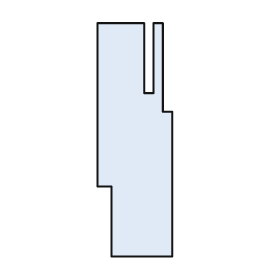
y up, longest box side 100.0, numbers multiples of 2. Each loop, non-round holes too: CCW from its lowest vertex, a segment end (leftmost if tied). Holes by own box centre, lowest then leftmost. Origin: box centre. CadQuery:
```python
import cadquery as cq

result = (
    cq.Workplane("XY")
    .moveTo(-10.0, -50.0)
    .lineTo(16.0, -50.0)
    .lineTo(16.0, 12.0)
    .lineTo(12.0, 12.0)
    .lineTo(12.0, 50.0)
    .lineTo(8.0, 50.0)
    .lineTo(8.0, 20.0)
    .lineTo(4.0, 20.0)
    .lineTo(4.0, 50.0)
    .lineTo(-16.0, 50.0)
    .lineTo(-16.0, -20.0)
    .lineTo(-10.0, -20.0)
    .close()
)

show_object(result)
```